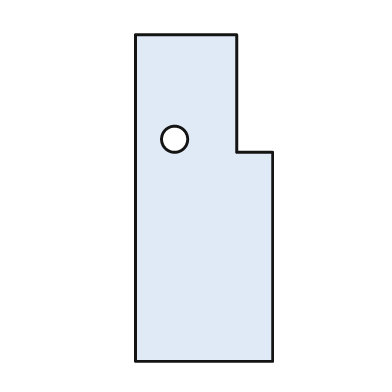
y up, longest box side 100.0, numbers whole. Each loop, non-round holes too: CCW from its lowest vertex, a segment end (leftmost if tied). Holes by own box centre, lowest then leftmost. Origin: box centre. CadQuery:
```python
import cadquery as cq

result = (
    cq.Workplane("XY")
    .moveTo(-21.0, -50.0)
    .lineTo(21.0, -50.0)
    .lineTo(21.0, 14.0)
    .lineTo(10.0, 14.0)
    .lineTo(10.0, 50.0)
    .lineTo(-21.0, 50.0)
    .close()
    .moveTo(-9.0, 18.0)
    .circle(4.0)
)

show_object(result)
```